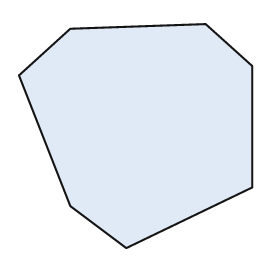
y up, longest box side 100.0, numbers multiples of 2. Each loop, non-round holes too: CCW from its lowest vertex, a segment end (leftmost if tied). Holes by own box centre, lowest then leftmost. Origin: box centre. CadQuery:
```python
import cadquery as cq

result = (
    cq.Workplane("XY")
    .moveTo(-4.0, -48.0)
    .lineTo(50.0, -22.0)
    .lineTo(50.0, 30.0)
    .lineTo(30.0, 48.0)
    .lineTo(-28.0, 46.0)
    .lineTo(-50.0, 26.0)
    .lineTo(-28.0, -30.0)
    .close()
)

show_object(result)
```